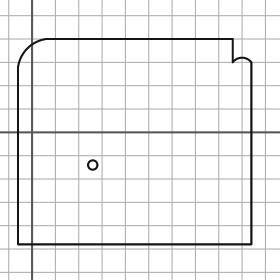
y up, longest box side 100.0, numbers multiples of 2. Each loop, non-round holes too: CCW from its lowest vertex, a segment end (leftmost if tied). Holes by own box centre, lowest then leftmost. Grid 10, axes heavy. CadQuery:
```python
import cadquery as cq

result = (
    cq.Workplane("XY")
    .moveTo(-6.0, -48.0)
    .lineTo(94.0, -48.0)
    .lineTo(94.0, 30.0)
    .threePointArc((90.0, 32.0), (86.0, 30.0))
    .lineTo(86.0, 40.0)
    .lineTo(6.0, 40.0)
    .threePointArc((-2.0, 36.0), (-6.0, 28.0))
    .close()
    .moveTo(26.0, -14.0)
    .circle(2.0)
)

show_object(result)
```